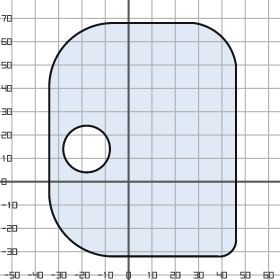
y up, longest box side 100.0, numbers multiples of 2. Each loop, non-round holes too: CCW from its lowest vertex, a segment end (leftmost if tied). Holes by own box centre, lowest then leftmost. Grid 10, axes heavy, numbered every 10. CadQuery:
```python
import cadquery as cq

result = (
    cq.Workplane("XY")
    .moveTo(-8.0, -32.0)
    .lineTo(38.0, -32.0)
    .threePointArc((44.0, -30.0), (46.0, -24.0))
    .lineTo(46.0, 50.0)
    .threePointArc((40.0, 62.0), (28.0, 68.0))
    .lineTo(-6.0, 68.0)
    .threePointArc((-26.0, 60.0), (-34.0, 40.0))
    .lineTo(-34.0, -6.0)
    .threePointArc((-26.0, -24.0), (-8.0, -32.0))
    .close()
    .moveTo(-18.0, 14.0)
    .circle(10.0)
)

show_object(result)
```